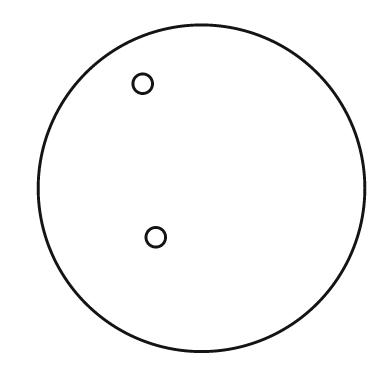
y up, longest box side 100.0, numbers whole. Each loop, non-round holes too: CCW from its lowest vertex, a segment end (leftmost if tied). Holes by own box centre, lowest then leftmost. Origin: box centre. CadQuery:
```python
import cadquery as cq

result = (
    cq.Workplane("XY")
    .moveTo(0.0, 0.0)
    .circle(50.0)
    .moveTo(-14.0, -15.0)
    .circle(3.0)
    .moveTo(-18.0, 32.0)
    .circle(3.0)
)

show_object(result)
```